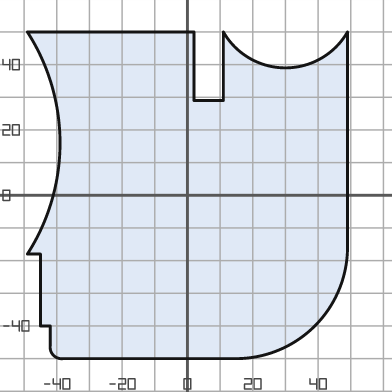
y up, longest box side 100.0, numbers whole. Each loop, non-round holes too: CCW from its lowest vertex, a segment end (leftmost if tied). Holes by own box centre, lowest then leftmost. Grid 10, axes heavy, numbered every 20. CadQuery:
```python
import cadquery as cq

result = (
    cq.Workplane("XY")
    .moveTo(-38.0, -50.0)
    .lineTo(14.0, -50.0)
    .threePointArc((39.0, -40.0), (49.0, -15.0))
    .lineTo(49.0, 50.0)
    .threePointArc((30.0, 39.0), (11.0, 50.0))
    .lineTo(11.0, 29.0)
    .lineTo(2.0, 29.0)
    .lineTo(2.0, 50.0)
    .lineTo(-49.0, 50.0)
    .threePointArc((-39.0, 16.0), (-49.0, -18.0))
    .lineTo(-45.0, -18.0)
    .lineTo(-45.0, -40.0)
    .lineTo(-42.0, -40.0)
    .lineTo(-42.0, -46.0)
    .threePointArc((-41.0, -49.0), (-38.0, -50.0))
    .close()
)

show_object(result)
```